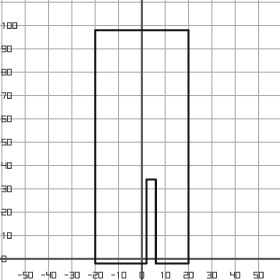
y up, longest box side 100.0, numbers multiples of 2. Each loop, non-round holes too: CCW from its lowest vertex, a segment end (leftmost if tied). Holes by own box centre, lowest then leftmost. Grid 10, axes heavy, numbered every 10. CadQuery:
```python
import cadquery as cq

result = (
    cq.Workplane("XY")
    .moveTo(-20.0, -2.0)
    .lineTo(2.0, -2.0)
    .lineTo(2.0, 34.0)
    .lineTo(6.0, 34.0)
    .lineTo(6.0, -2.0)
    .lineTo(20.0, -2.0)
    .lineTo(20.0, 98.0)
    .lineTo(-20.0, 98.0)
    .close()
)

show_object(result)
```